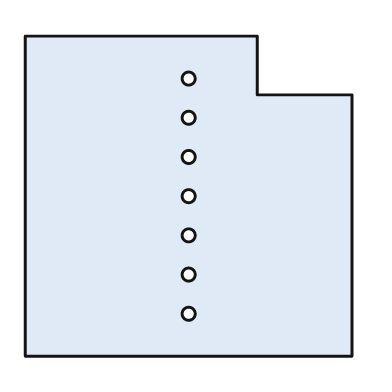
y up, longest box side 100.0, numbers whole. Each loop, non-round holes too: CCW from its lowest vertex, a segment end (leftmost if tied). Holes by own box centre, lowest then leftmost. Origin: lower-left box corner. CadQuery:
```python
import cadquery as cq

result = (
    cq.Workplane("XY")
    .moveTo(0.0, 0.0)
    .lineTo(100.0, 0.0)
    .lineTo(100.0, 80.0)
    .lineTo(71.0, 80.0)
    .lineTo(71.0, 98.0)
    .lineTo(0.0, 98.0)
    .close()
    .moveTo(50.0, 13.0)
    .circle(2.0)
    .moveTo(50.0, 25.0)
    .circle(2.0)
    .moveTo(50.0, 37.0)
    .circle(2.0)
    .moveTo(50.0, 49.0)
    .circle(2.0)
    .moveTo(50.0, 61.0)
    .circle(2.0)
    .moveTo(50.0, 73.0)
    .circle(2.0)
    .moveTo(50.0, 85.0)
    .circle(2.0)
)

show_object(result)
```